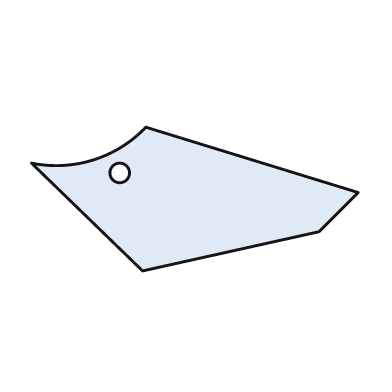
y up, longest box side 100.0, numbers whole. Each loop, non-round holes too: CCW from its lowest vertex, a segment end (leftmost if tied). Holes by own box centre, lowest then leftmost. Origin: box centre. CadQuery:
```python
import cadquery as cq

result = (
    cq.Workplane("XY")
    .moveTo(-16.0, -22.0)
    .lineTo(38.0, -10.0)
    .lineTo(50.0, 2.0)
    .lineTo(-15.0, 22.0)
    .threePointArc((-31.0, 12.0), (-50.0, 11.0))
    .close()
    .moveTo(-23.0, 8.0)
    .circle(3.0)
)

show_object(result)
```